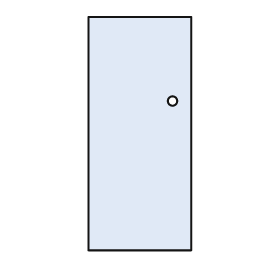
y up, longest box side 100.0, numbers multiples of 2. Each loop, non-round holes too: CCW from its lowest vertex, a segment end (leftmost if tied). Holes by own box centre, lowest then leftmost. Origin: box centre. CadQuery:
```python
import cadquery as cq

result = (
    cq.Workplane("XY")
    .moveTo(-22.0, -50.0)
    .lineTo(22.0, -50.0)
    .lineTo(22.0, 50.0)
    .lineTo(-22.0, 50.0)
    .close()
    .moveTo(14.0, 14.0)
    .circle(2.0)
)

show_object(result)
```